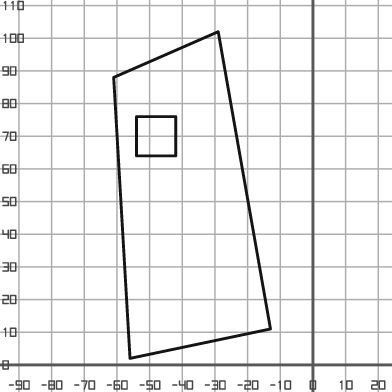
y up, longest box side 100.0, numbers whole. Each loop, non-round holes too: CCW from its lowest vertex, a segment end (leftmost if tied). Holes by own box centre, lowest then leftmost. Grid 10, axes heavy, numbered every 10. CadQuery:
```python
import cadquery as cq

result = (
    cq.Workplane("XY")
    .moveTo(-56.0, 2.0)
    .lineTo(-13.0, 11.0)
    .lineTo(-29.0, 102.0)
    .lineTo(-61.0, 88.0)
    .close()
    .moveTo(-54.0, 64.0)
    .lineTo(-42.0, 64.0)
    .lineTo(-42.0, 76.0)
    .lineTo(-54.0, 76.0)
    .close()
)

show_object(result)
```